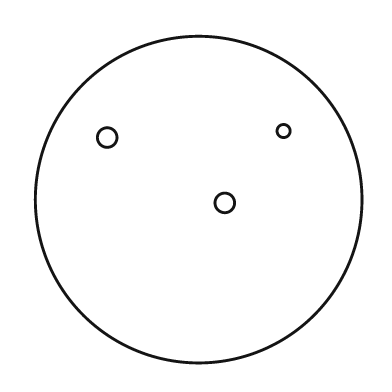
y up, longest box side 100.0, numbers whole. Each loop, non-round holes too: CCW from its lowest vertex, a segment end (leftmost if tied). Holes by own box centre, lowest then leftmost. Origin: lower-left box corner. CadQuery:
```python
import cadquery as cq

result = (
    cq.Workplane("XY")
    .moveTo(50.0, 50.0)
    .circle(50.0)
    .moveTo(58.0, 49.0)
    .circle(3.0)
    .moveTo(22.0, 69.0)
    .circle(3.0)
    .moveTo(76.0, 71.0)
    .circle(2.0)
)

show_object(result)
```